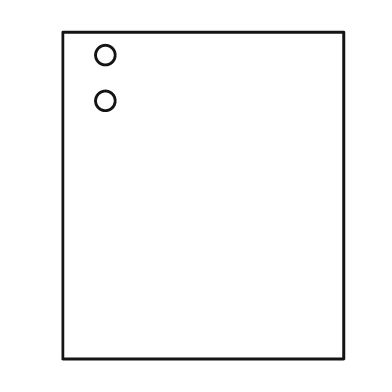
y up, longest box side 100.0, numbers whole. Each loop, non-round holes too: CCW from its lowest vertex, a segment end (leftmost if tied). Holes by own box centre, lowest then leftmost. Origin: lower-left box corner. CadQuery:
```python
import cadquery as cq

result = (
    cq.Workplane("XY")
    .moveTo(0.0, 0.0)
    .lineTo(86.0, 0.0)
    .lineTo(86.0, 100.0)
    .lineTo(0.0, 100.0)
    .close()
    .moveTo(13.0, 79.0)
    .circle(3.0)
    .moveTo(13.0, 93.0)
    .circle(3.0)
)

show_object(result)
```